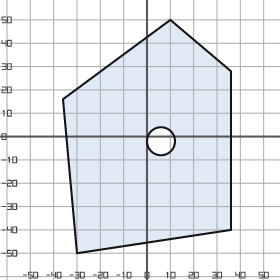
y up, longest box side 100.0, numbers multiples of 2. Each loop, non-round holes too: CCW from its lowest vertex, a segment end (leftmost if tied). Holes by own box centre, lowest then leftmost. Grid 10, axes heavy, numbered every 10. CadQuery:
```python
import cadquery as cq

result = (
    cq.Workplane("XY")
    .moveTo(-30.0, -50.0)
    .lineTo(36.0, -40.0)
    .lineTo(36.0, 28.0)
    .lineTo(10.0, 50.0)
    .lineTo(-36.0, 16.0)
    .close()
    .moveTo(6.0, -2.0)
    .circle(6.0)
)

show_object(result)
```